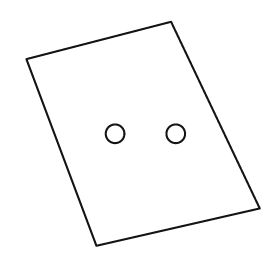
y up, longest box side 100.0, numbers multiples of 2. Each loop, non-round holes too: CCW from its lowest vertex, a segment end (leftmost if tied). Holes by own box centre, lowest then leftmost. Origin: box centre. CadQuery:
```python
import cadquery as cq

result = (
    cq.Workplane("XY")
    .moveTo(-20.0, -48.0)
    .lineTo(50.0, -32.0)
    .lineTo(12.0, 48.0)
    .lineTo(-50.0, 32.0)
    .close()
    .moveTo(-12.0, 0.0)
    .circle(4.0)
    .moveTo(14.0, 0.0)
    .circle(4.0)
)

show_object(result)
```